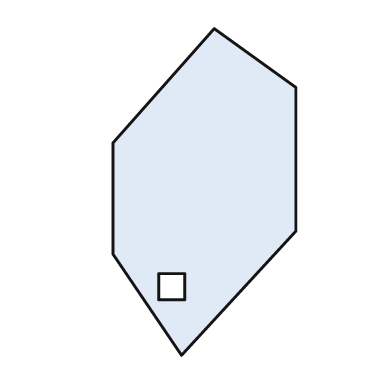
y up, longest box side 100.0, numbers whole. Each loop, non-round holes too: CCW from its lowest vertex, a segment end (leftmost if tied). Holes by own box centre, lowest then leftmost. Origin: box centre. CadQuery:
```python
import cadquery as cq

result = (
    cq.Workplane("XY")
    .moveTo(-7.0, -50.0)
    .lineTo(28.0, -12.0)
    .lineTo(28.0, 32.0)
    .lineTo(3.0, 50.0)
    .lineTo(-28.0, 15.0)
    .lineTo(-28.0, -19.0)
    .close()
    .moveTo(-14.0, -33.0)
    .lineTo(-6.0, -33.0)
    .lineTo(-6.0, -25.0)
    .lineTo(-14.0, -25.0)
    .close()
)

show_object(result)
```